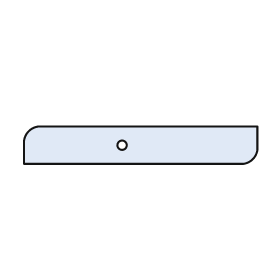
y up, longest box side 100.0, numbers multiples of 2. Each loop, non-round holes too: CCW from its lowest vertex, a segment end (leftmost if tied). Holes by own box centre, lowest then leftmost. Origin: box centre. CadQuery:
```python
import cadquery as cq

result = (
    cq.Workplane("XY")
    .moveTo(-50.0, -8.0)
    .lineTo(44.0, -8.0)
    .threePointArc((48.0, -6.0), (50.0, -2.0))
    .lineTo(50.0, 8.0)
    .lineTo(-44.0, 8.0)
    .threePointArc((-48.0, 6.0), (-50.0, 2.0))
    .close()
    .moveTo(-8.0, 0.0)
    .circle(2.0)
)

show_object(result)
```